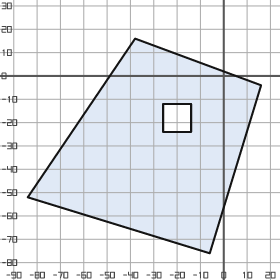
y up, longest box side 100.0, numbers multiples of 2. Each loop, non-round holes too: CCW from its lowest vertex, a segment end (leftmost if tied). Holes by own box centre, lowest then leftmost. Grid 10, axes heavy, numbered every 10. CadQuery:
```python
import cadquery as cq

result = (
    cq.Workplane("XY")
    .moveTo(-6.0, -76.0)
    .lineTo(16.0, -4.0)
    .lineTo(-38.0, 16.0)
    .lineTo(-84.0, -52.0)
    .close()
    .moveTo(-26.0, -24.0)
    .lineTo(-14.0, -24.0)
    .lineTo(-14.0, -12.0)
    .lineTo(-26.0, -12.0)
    .close()
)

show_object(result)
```